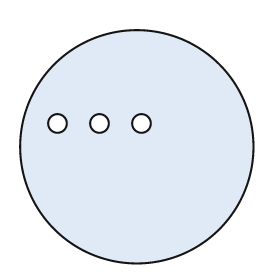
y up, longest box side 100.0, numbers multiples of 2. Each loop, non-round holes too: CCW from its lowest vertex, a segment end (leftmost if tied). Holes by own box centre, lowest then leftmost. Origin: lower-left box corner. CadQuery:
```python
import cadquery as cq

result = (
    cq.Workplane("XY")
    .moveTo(50.0, 50.0)
    .circle(50.0)
    .moveTo(16.0, 60.0)
    .circle(4.0)
    .moveTo(34.0, 60.0)
    .circle(4.0)
    .moveTo(52.0, 60.0)
    .circle(4.0)
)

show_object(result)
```